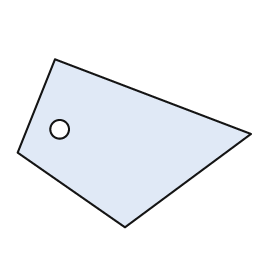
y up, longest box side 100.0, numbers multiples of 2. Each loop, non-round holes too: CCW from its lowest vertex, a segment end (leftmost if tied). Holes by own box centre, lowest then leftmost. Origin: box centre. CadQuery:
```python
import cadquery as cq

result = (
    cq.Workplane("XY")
    .moveTo(-4.0, -36.0)
    .lineTo(50.0, 4.0)
    .lineTo(-34.0, 36.0)
    .lineTo(-50.0, -4.0)
    .close()
    .moveTo(-32.0, 6.0)
    .circle(4.0)
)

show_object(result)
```